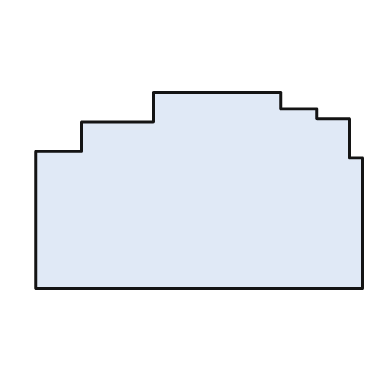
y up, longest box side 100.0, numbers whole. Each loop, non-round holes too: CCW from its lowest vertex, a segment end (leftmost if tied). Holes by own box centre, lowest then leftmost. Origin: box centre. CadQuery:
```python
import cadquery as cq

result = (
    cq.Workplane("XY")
    .moveTo(-50.0, -30.0)
    .lineTo(50.0, -30.0)
    .lineTo(50.0, 10.0)
    .lineTo(46.0, 10.0)
    .lineTo(46.0, 22.0)
    .lineTo(36.0, 22.0)
    .lineTo(36.0, 25.0)
    .lineTo(25.0, 25.0)
    .lineTo(25.0, 30.0)
    .lineTo(-14.0, 30.0)
    .lineTo(-14.0, 21.0)
    .lineTo(-36.0, 21.0)
    .lineTo(-36.0, 12.0)
    .lineTo(-50.0, 12.0)
    .close()
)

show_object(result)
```